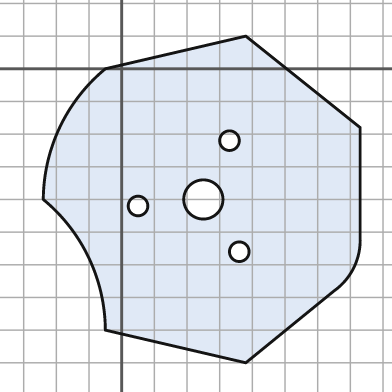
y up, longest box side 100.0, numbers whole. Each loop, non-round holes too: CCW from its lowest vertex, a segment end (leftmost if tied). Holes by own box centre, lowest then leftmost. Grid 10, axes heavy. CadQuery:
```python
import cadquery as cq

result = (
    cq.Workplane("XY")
    .moveTo(38.0, -90.0)
    .lineTo(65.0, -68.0)
    .threePointArc((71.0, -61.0), (73.0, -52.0))
    .lineTo(73.0, -18.0)
    .lineTo(38.0, 10.0)
    .lineTo(-5.0, 0.0)
    .threePointArc((-19.0, -18.0), (-24.0, -40.0))
    .threePointArc((-10.0, -58.0), (-5.0, -80.0))
    .close()
    .moveTo(36.0, -56.0)
    .circle(3.0)
    .moveTo(5.0, -42.0)
    .circle(3.0)
    .moveTo(25.0, -40.0)
    .circle(6.0)
    .moveTo(33.0, -22.0)
    .circle(3.0)
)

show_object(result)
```